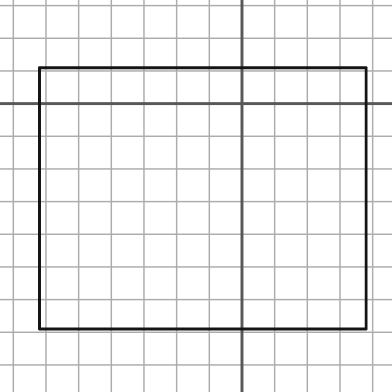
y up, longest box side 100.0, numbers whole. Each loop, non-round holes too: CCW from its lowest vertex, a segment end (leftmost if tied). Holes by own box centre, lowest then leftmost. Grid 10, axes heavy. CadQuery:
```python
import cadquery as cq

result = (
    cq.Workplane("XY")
    .moveTo(-62.0, -69.0)
    .lineTo(38.0, -69.0)
    .lineTo(38.0, 11.0)
    .lineTo(-62.0, 11.0)
    .close()
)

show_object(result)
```